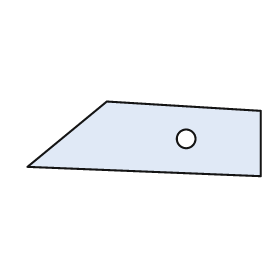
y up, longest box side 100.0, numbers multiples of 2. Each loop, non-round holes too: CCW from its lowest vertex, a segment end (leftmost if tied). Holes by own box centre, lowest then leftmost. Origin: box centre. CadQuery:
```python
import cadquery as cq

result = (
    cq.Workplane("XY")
    .moveTo(50.0, -16.0)
    .lineTo(50.0, 12.0)
    .lineTo(-16.0, 16.0)
    .lineTo(-50.0, -12.0)
    .close()
    .moveTo(18.0, 0.0)
    .circle(4.0)
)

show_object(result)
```